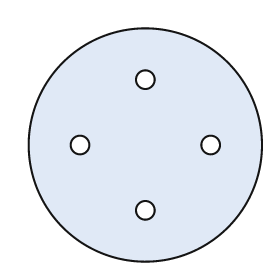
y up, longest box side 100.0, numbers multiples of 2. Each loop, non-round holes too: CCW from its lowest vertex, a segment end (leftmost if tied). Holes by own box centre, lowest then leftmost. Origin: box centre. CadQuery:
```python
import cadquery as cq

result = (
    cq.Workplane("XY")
    .moveTo(0.0, 0.0)
    .circle(50.0)
    .moveTo(0.0, -28.0)
    .circle(4.0)
    .moveTo(-28.0, 0.0)
    .circle(4.0)
    .moveTo(28.0, 0.0)
    .circle(4.0)
    .moveTo(0.0, 28.0)
    .circle(4.0)
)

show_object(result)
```